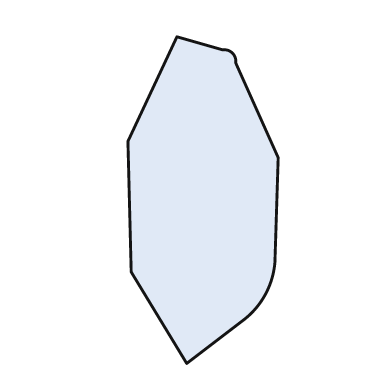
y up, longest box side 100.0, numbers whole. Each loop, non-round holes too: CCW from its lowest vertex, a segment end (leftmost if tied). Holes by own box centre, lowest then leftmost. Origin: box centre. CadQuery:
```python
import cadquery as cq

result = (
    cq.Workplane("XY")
    .moveTo(-5.0, -50.0)
    .lineTo(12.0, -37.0)
    .threePointArc((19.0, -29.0), (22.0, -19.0))
    .lineTo(23.0, 13.0)
    .lineTo(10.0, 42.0)
    .threePointArc((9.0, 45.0), (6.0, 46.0))
    .lineTo(-8.0, 50.0)
    .lineTo(-23.0, 18.0)
    .lineTo(-22.0, -22.0)
    .close()
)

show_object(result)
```